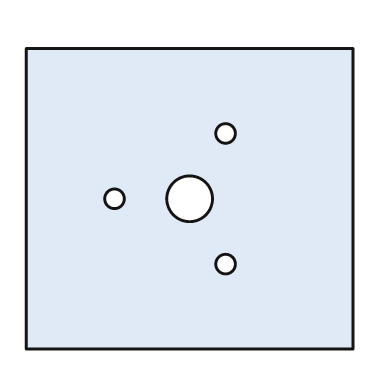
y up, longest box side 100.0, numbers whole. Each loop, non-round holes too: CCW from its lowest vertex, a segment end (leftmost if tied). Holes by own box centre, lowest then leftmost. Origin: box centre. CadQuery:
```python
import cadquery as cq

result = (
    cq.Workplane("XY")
    .moveTo(-50.0, -46.0)
    .lineTo(50.0, -46.0)
    .lineTo(50.0, 46.0)
    .lineTo(-50.0, 46.0)
    .close()
    .moveTo(11.0, -20.0)
    .circle(3.0)
    .moveTo(-23.0, 0.0)
    .circle(3.0)
    .moveTo(0.0, 0.0)
    .circle(7.0)
    .moveTo(11.0, 20.0)
    .circle(3.0)
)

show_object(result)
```